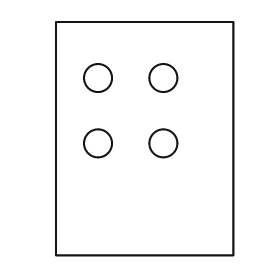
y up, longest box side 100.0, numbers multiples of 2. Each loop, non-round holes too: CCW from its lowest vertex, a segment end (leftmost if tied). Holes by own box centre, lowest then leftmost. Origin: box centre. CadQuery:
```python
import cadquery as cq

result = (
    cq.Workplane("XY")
    .moveTo(-38.0, -50.0)
    .lineTo(38.0, -50.0)
    .lineTo(38.0, 50.0)
    .lineTo(-38.0, 50.0)
    .close()
    .moveTo(-20.0, -2.0)
    .circle(6.0)
    .moveTo(8.0, -2.0)
    .circle(6.0)
    .moveTo(-20.0, 26.0)
    .circle(6.0)
    .moveTo(8.0, 26.0)
    .circle(6.0)
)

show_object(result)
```